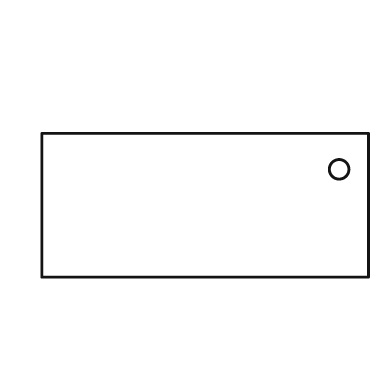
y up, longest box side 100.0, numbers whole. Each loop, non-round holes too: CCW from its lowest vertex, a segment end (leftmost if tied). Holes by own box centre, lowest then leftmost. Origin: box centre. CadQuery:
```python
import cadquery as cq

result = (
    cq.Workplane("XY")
    .moveTo(-50.0, -22.0)
    .lineTo(50.0, -22.0)
    .lineTo(50.0, 22.0)
    .lineTo(-50.0, 22.0)
    .close()
    .moveTo(41.0, 11.0)
    .circle(3.0)
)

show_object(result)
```